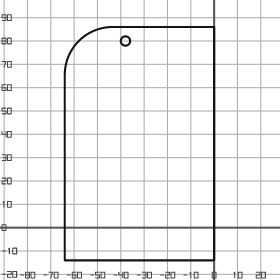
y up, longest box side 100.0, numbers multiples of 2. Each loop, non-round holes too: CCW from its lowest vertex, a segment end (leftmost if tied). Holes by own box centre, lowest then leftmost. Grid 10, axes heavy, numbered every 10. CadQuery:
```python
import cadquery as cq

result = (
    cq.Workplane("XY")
    .moveTo(-64.0, -14.0)
    .lineTo(0.0, -14.0)
    .lineTo(0.0, 86.0)
    .lineTo(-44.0, 86.0)
    .threePointArc((-58.0, 80.0), (-64.0, 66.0))
    .close()
    .moveTo(-38.0, 80.0)
    .circle(2.0)
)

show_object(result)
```